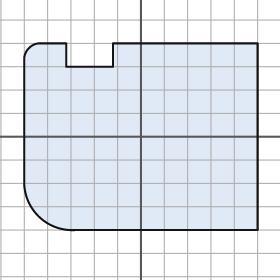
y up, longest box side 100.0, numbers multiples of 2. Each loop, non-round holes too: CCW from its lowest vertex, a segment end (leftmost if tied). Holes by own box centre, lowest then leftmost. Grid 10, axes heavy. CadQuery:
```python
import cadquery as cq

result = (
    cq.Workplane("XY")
    .moveTo(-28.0, -40.0)
    .lineTo(50.0, -40.0)
    .lineTo(50.0, 40.0)
    .lineTo(-12.0, 40.0)
    .lineTo(-12.0, 30.0)
    .lineTo(-32.0, 30.0)
    .lineTo(-32.0, 40.0)
    .lineTo(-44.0, 40.0)
    .threePointArc((-48.0, 38.0), (-50.0, 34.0))
    .lineTo(-50.0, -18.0)
    .threePointArc((-44.0, -34.0), (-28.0, -40.0))
    .close()
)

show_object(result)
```